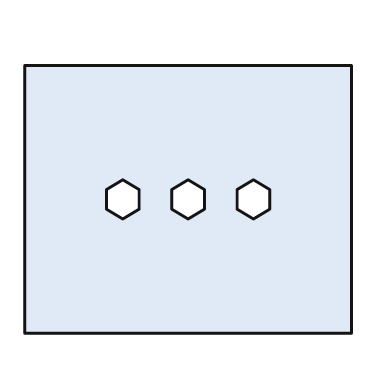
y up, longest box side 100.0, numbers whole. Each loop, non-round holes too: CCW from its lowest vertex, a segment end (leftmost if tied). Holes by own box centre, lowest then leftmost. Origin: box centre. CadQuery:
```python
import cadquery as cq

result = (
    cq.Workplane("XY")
    .moveTo(-50.0, -41.0)
    .lineTo(50.0, -41.0)
    .lineTo(50.0, 41.0)
    .lineTo(-50.0, 41.0)
    .close()
    .moveTo(-20.0, -6.0)
    .lineTo(-15.0, -3.0)
    .lineTo(-15.0, 3.0)
    .lineTo(-20.0, 6.0)
    .lineTo(-25.0, 3.0)
    .lineTo(-25.0, -3.0)
    .close()
    .moveTo(0.0, -6.0)
    .lineTo(5.0, -3.0)
    .lineTo(5.0, 3.0)
    .lineTo(0.0, 6.0)
    .lineTo(-5.0, 3.0)
    .lineTo(-5.0, -3.0)
    .close()
    .moveTo(20.0, -6.0)
    .lineTo(25.0, -3.0)
    .lineTo(25.0, 3.0)
    .lineTo(20.0, 6.0)
    .lineTo(15.0, 3.0)
    .lineTo(15.0, -3.0)
    .close()
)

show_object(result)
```